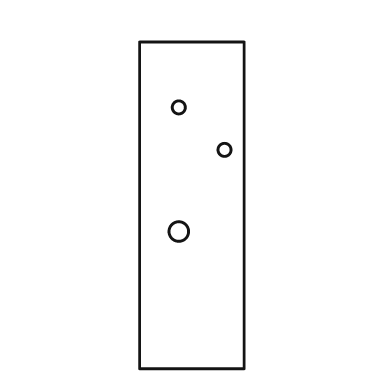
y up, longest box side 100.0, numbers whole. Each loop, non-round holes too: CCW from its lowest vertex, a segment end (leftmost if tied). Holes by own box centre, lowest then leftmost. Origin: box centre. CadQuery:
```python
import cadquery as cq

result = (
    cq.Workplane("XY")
    .moveTo(-16.0, -50.0)
    .lineTo(16.0, -50.0)
    .lineTo(16.0, 50.0)
    .lineTo(-16.0, 50.0)
    .close()
    .moveTo(-4.0, -8.0)
    .circle(3.0)
    .moveTo(10.0, 17.0)
    .circle(2.0)
    .moveTo(-4.0, 30.0)
    .circle(2.0)
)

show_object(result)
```